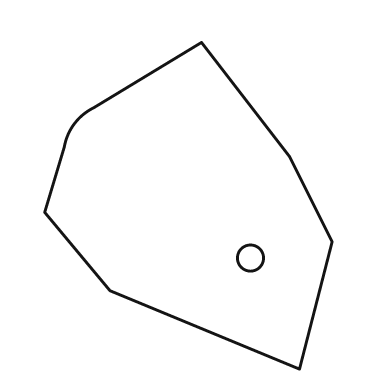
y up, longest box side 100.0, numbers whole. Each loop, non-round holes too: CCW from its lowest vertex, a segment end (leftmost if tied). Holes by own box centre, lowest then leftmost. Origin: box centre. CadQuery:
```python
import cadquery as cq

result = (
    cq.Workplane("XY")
    .moveTo(34.0, -50.0)
    .lineTo(44.0, -11.0)
    .lineTo(31.0, 15.0)
    .lineTo(4.0, 50.0)
    .lineTo(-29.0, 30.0)
    .threePointArc((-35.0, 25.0), (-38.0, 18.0))
    .lineTo(-44.0, -2.0)
    .lineTo(-24.0, -26.0)
    .close()
    .moveTo(19.0, -16.0)
    .circle(4.0)
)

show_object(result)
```